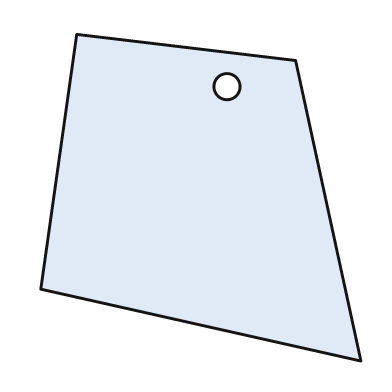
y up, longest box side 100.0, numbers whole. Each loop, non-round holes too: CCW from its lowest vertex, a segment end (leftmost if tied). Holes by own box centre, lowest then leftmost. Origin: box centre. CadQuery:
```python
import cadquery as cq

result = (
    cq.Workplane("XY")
    .moveTo(49.0, -50.0)
    .lineTo(29.0, 42.0)
    .lineTo(-38.0, 50.0)
    .lineTo(-49.0, -28.0)
    .close()
    .moveTo(8.0, 34.0)
    .circle(4.0)
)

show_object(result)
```